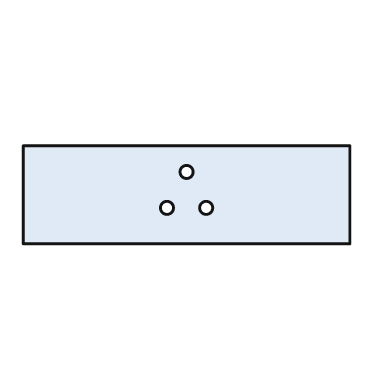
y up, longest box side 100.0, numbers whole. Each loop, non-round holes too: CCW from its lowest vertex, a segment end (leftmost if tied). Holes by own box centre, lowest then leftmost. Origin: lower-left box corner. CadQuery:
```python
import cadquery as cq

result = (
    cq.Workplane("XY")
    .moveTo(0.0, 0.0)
    .lineTo(100.0, 0.0)
    .lineTo(100.0, 30.0)
    .lineTo(0.0, 30.0)
    .close()
    .moveTo(44.0, 11.0)
    .circle(2.0)
    .moveTo(56.0, 11.0)
    .circle(2.0)
    .moveTo(50.0, 22.0)
    .circle(2.0)
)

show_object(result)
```